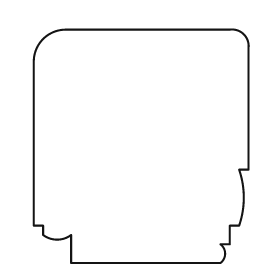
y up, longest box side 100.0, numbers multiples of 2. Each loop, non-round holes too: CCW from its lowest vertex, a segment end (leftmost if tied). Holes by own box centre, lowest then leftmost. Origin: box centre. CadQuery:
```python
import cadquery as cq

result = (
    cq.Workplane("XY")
    .moveTo(-30.0, -50.0)
    .lineTo(34.0, -50.0)
    .threePointArc((36.0, -46.0), (34.0, -42.0))
    .lineTo(38.0, -42.0)
    .lineTo(38.0, -34.0)
    .lineTo(42.0, -34.0)
    .threePointArc((44.0, -22.0), (42.0, -10.0))
    .lineTo(46.0, -10.0)
    .lineTo(46.0, 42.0)
    .threePointArc((44.0, 48.0), (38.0, 50.0))
    .lineTo(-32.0, 50.0)
    .threePointArc((-42.0, 46.0), (-46.0, 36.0))
    .lineTo(-46.0, -34.0)
    .lineTo(-42.0, -34.0)
    .lineTo(-42.0, -38.0)
    .threePointArc((-36.0, -40.0), (-30.0, -38.0))
    .close()
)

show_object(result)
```